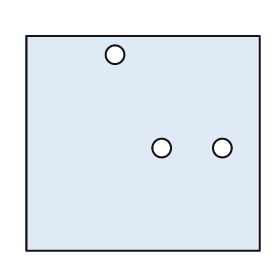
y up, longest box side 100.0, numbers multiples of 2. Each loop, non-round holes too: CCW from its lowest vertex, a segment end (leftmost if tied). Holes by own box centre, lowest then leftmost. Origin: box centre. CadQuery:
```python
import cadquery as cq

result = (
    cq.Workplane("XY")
    .moveTo(-50.0, -46.0)
    .lineTo(50.0, -46.0)
    .lineTo(50.0, 46.0)
    .lineTo(-50.0, 46.0)
    .close()
    .moveTo(8.0, -2.0)
    .circle(4.0)
    .moveTo(34.0, -2.0)
    .circle(4.0)
    .moveTo(-12.0, 38.0)
    .circle(4.0)
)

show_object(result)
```